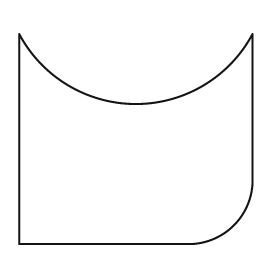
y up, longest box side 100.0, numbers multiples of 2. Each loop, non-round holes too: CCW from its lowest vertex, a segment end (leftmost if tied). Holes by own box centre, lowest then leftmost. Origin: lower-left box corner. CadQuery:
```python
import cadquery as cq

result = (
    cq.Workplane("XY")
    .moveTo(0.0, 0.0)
    .lineTo(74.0, 0.0)
    .threePointArc((92.0, 8.0), (100.0, 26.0))
    .lineTo(100.0, 90.0)
    .threePointArc((50.0, 60.0), (0.0, 90.0))
    .close()
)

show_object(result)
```